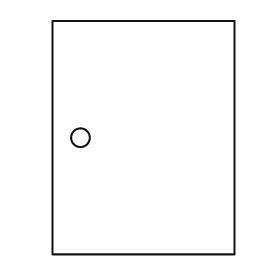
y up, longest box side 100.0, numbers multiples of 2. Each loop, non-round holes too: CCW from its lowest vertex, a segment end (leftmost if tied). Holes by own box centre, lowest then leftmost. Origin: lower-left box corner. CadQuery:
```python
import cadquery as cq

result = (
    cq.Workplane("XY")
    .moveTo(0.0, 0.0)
    .lineTo(78.0, 0.0)
    .lineTo(78.0, 100.0)
    .lineTo(0.0, 100.0)
    .close()
    .moveTo(12.0, 50.0)
    .circle(4.0)
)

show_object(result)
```